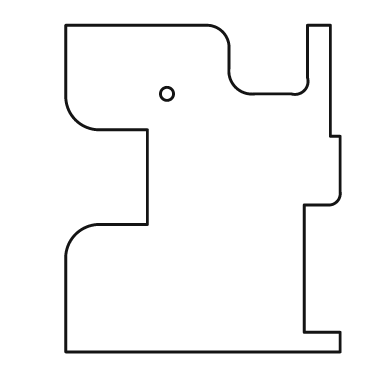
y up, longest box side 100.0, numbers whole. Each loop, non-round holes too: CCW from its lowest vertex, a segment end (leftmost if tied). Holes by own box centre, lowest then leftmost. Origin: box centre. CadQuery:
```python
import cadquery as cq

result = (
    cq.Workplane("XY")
    .moveTo(-42.0, -50.0)
    .lineTo(42.0, -50.0)
    .lineTo(42.0, -44.0)
    .lineTo(31.0, -44.0)
    .lineTo(31.0, -5.0)
    .lineTo(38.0, -5.0)
    .threePointArc((41.0, -4.0), (42.0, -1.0))
    .lineTo(42.0, 16.0)
    .lineTo(39.0, 16.0)
    .lineTo(39.0, 50.0)
    .lineTo(32.0, 50.0)
    .lineTo(32.0, 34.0)
    .threePointArc((31.0, 30.0), (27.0, 29.0))
    .lineTo(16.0, 29.0)
    .threePointArc((10.0, 31.0), (8.0, 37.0))
    .lineTo(8.0, 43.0)
    .threePointArc((6.0, 48.0), (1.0, 50.0))
    .lineTo(-42.0, 50.0)
    .lineTo(-42.0, 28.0)
    .threePointArc((-39.0, 21.0), (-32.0, 18.0))
    .lineTo(-17.0, 18.0)
    .lineTo(-17.0, -11.0)
    .lineTo(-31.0, -11.0)
    .threePointArc((-39.0, -14.0), (-42.0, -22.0))
    .close()
    .moveTo(-11.0, 29.0)
    .circle(2.0)
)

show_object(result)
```